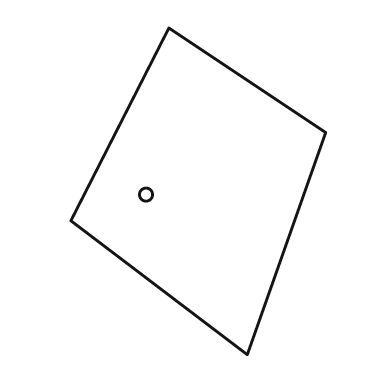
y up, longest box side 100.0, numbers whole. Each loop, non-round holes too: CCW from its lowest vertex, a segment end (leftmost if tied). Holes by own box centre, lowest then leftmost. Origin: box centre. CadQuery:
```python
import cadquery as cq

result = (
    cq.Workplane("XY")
    .moveTo(15.0, -50.0)
    .lineTo(39.0, 18.0)
    .lineTo(-9.0, 50.0)
    .lineTo(-39.0, -9.0)
    .close()
    .moveTo(-16.0, -1.0)
    .circle(2.0)
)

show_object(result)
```